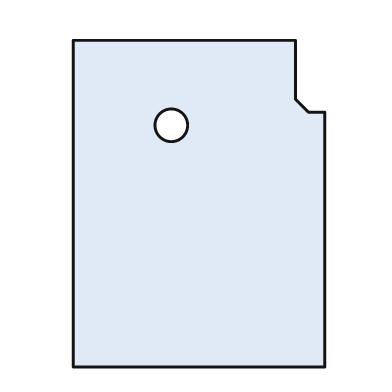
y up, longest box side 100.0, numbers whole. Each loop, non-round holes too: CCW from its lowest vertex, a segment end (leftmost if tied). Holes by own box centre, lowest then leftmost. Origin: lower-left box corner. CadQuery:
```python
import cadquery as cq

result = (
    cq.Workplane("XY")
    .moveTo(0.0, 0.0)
    .lineTo(77.0, 0.0)
    .lineTo(77.0, 78.0)
    .lineTo(72.0, 78.0)
    .lineTo(68.0, 82.0)
    .lineTo(68.0, 100.0)
    .lineTo(0.0, 100.0)
    .close()
    .moveTo(30.0, 74.0)
    .circle(5.0)
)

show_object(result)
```